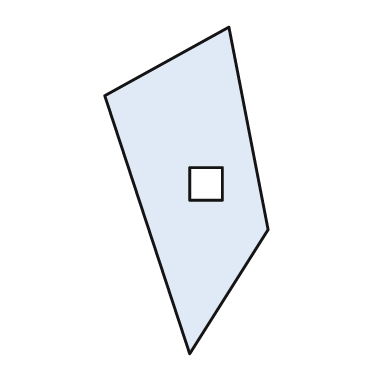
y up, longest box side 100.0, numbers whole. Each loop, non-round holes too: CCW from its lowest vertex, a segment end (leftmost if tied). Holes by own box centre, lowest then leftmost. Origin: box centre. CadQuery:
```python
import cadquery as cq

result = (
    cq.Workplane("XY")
    .moveTo(1.0, -50.0)
    .lineTo(25.0, -12.0)
    .lineTo(13.0, 50.0)
    .lineTo(-25.0, 29.0)
    .close()
    .moveTo(1.0, -3.0)
    .lineTo(11.0, -3.0)
    .lineTo(11.0, 7.0)
    .lineTo(1.0, 7.0)
    .close()
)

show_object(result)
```